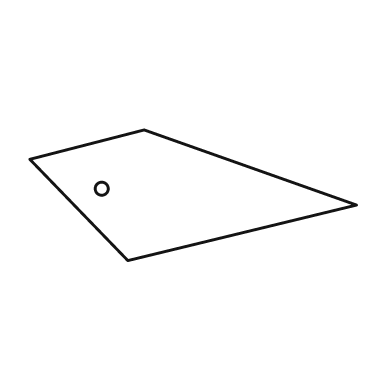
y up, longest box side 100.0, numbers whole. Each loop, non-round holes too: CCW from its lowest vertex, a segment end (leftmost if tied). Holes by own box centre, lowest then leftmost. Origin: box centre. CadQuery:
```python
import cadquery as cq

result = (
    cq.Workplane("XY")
    .moveTo(-20.0, -20.0)
    .lineTo(50.0, -3.0)
    .lineTo(-15.0, 20.0)
    .lineTo(-50.0, 11.0)
    .close()
    .moveTo(-28.0, 2.0)
    .circle(2.0)
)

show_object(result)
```